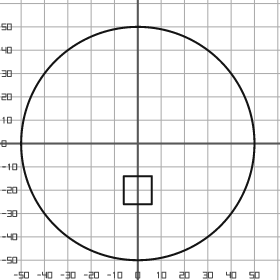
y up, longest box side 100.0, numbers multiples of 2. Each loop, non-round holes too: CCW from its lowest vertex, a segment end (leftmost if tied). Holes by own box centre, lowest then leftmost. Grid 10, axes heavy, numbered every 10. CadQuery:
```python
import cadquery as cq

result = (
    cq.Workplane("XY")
    .moveTo(0.0, 0.0)
    .circle(50.0)
    .moveTo(-6.0, -26.0)
    .lineTo(6.0, -26.0)
    .lineTo(6.0, -14.0)
    .lineTo(-6.0, -14.0)
    .close()
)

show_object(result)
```